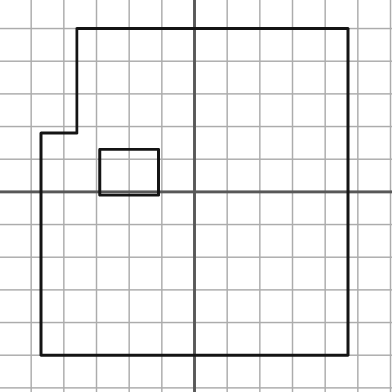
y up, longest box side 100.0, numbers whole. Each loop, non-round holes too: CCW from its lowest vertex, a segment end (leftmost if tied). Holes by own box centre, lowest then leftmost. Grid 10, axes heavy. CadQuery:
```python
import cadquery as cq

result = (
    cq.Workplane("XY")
    .moveTo(-47.0, -50.0)
    .lineTo(47.0, -50.0)
    .lineTo(47.0, 50.0)
    .lineTo(-36.0, 50.0)
    .lineTo(-36.0, 18.0)
    .lineTo(-47.0, 18.0)
    .close()
    .moveTo(-29.0, -1.0)
    .lineTo(-11.0, -1.0)
    .lineTo(-11.0, 13.0)
    .lineTo(-29.0, 13.0)
    .close()
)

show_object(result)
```